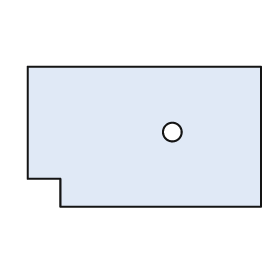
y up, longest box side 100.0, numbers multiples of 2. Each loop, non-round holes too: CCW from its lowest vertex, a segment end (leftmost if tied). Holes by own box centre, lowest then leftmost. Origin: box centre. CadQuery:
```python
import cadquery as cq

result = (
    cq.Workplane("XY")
    .moveTo(-36.0, -30.0)
    .lineTo(50.0, -30.0)
    .lineTo(50.0, 30.0)
    .lineTo(-50.0, 30.0)
    .lineTo(-50.0, -18.0)
    .lineTo(-36.0, -18.0)
    .close()
    .moveTo(12.0, 2.0)
    .circle(4.0)
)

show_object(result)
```